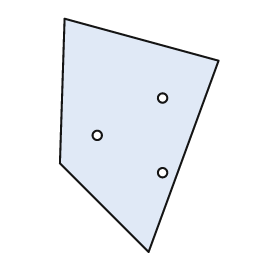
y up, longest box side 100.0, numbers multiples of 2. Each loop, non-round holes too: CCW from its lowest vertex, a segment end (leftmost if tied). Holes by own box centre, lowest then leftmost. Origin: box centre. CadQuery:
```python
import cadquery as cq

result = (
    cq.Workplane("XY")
    .moveTo(4.0, -50.0)
    .lineTo(34.0, 32.0)
    .lineTo(-32.0, 50.0)
    .lineTo(-34.0, -12.0)
    .close()
    .moveTo(10.0, -16.0)
    .circle(2.0)
    .moveTo(-18.0, 0.0)
    .circle(2.0)
    .moveTo(10.0, 16.0)
    .circle(2.0)
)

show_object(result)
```